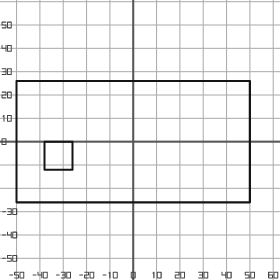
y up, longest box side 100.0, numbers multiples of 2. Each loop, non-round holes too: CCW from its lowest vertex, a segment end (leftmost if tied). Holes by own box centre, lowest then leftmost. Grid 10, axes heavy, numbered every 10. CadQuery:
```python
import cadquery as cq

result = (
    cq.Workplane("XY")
    .moveTo(-50.0, -26.0)
    .lineTo(50.0, -26.0)
    .lineTo(50.0, 26.0)
    .lineTo(-50.0, 26.0)
    .close()
    .moveTo(-38.0, -12.0)
    .lineTo(-26.0, -12.0)
    .lineTo(-26.0, 0.0)
    .lineTo(-38.0, 0.0)
    .close()
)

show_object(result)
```